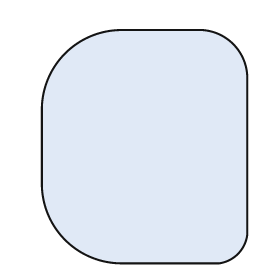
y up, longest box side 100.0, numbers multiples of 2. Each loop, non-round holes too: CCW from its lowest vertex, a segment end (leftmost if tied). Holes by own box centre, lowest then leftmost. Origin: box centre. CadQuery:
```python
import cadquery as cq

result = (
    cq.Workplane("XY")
    .moveTo(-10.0, -50.0)
    .lineTo(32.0, -50.0)
    .threePointArc((40.0, -46.0), (44.0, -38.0))
    .lineTo(44.0, 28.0)
    .threePointArc((38.0, 44.0), (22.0, 50.0))
    .lineTo(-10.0, 50.0)
    .threePointArc((-34.0, 40.0), (-44.0, 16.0))
    .lineTo(-44.0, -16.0)
    .threePointArc((-34.0, -40.0), (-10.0, -50.0))
    .close()
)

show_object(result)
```